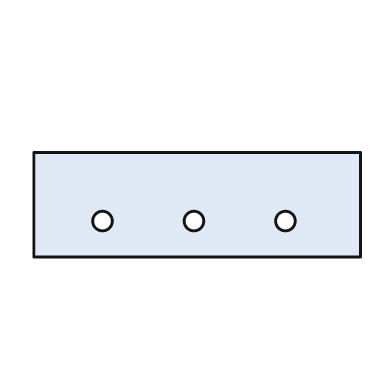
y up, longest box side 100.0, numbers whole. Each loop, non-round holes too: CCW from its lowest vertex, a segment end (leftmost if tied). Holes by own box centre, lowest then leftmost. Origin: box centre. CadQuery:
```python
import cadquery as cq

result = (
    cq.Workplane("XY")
    .moveTo(-50.0, -16.0)
    .lineTo(50.0, -16.0)
    .lineTo(50.0, 16.0)
    .lineTo(-50.0, 16.0)
    .close()
    .moveTo(-29.0, -5.0)
    .circle(3.0)
    .moveTo(-1.0, -5.0)
    .circle(3.0)
    .moveTo(27.0, -5.0)
    .circle(3.0)
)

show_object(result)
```